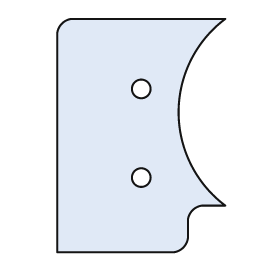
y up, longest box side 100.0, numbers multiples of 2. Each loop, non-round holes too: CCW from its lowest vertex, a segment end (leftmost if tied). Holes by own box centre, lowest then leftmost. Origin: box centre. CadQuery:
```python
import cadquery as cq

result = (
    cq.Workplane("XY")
    .moveTo(-36.0, -50.0)
    .lineTo(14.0, -50.0)
    .threePointArc((18.0, -48.0), (20.0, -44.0))
    .lineTo(20.0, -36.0)
    .threePointArc((22.0, -32.0), (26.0, -30.0))
    .lineTo(36.0, -30.0)
    .threePointArc((16.0, 10.0), (36.0, 50.0))
    .lineTo(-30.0, 50.0)
    .threePointArc((-34.0, 48.0), (-36.0, 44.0))
    .close()
    .moveTo(0.0, -18.0)
    .circle(4.0)
    .moveTo(0.0, 20.0)
    .circle(4.0)
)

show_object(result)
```